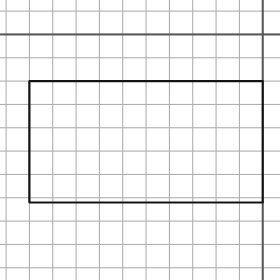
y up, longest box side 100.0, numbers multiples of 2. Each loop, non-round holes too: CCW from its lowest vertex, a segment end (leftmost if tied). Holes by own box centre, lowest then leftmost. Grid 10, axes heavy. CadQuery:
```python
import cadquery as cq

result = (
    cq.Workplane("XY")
    .moveTo(-100.0, -72.0)
    .lineTo(0.0, -72.0)
    .lineTo(0.0, -20.0)
    .lineTo(-100.0, -20.0)
    .close()
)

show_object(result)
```